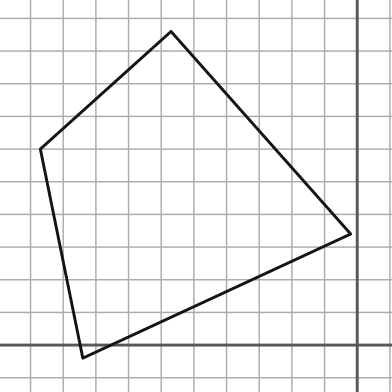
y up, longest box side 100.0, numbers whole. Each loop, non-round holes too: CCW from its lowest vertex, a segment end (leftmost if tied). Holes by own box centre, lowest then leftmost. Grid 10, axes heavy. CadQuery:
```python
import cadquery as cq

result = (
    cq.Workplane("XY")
    .moveTo(-84.0, -4.0)
    .lineTo(-2.0, 34.0)
    .lineTo(-57.0, 96.0)
    .lineTo(-97.0, 60.0)
    .close()
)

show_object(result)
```